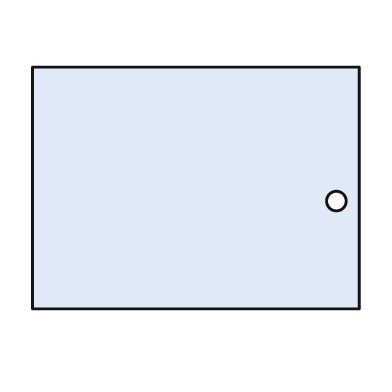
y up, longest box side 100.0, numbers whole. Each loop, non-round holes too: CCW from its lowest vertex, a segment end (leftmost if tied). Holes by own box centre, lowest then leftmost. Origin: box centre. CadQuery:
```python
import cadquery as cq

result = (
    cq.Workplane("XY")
    .moveTo(-50.0, -37.0)
    .lineTo(50.0, -37.0)
    .lineTo(50.0, 37.0)
    .lineTo(-50.0, 37.0)
    .close()
    .moveTo(43.0, -4.0)
    .circle(3.0)
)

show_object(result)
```